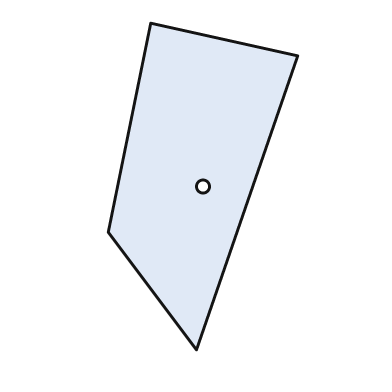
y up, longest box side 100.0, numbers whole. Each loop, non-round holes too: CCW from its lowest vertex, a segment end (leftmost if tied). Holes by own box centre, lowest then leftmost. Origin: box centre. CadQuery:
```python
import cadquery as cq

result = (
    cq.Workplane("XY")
    .moveTo(-2.0, -50.0)
    .lineTo(29.0, 40.0)
    .lineTo(-16.0, 50.0)
    .lineTo(-29.0, -14.0)
    .close()
    .moveTo(0.0, 0.0)
    .circle(2.0)
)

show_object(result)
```